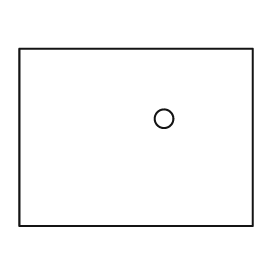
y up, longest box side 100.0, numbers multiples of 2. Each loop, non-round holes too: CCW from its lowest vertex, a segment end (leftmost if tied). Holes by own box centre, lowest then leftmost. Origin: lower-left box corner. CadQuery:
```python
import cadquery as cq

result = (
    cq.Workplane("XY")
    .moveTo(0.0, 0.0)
    .lineTo(100.0, 0.0)
    .lineTo(100.0, 76.0)
    .lineTo(0.0, 76.0)
    .close()
    .moveTo(62.0, 46.0)
    .circle(4.0)
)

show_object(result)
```